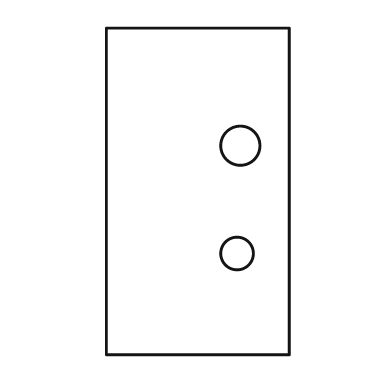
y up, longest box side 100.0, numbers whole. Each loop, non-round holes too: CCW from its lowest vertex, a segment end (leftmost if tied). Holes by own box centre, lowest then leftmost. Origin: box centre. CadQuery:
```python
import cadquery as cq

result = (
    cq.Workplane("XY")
    .moveTo(-28.0, -50.0)
    .lineTo(28.0, -50.0)
    .lineTo(28.0, 50.0)
    .lineTo(-28.0, 50.0)
    .close()
    .moveTo(12.0, -19.0)
    .circle(5.0)
    .moveTo(13.0, 14.0)
    .circle(6.0)
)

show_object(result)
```